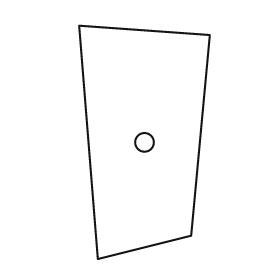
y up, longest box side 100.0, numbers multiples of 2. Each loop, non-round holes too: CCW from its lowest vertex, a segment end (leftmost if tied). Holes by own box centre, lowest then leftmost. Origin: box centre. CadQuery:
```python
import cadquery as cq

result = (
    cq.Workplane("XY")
    .moveTo(-20.0, -50.0)
    .lineTo(20.0, -40.0)
    .lineTo(28.0, 46.0)
    .lineTo(-28.0, 50.0)
    .close()
    .moveTo(0.0, 0.0)
    .circle(4.0)
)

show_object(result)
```